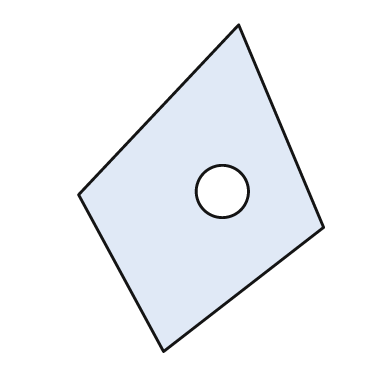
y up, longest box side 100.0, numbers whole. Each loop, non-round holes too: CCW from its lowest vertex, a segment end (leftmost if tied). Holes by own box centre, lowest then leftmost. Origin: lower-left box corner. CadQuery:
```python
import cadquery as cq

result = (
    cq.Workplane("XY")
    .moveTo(26.0, 0.0)
    .lineTo(75.0, 38.0)
    .lineTo(49.0, 100.0)
    .lineTo(0.0, 48.0)
    .close()
    .moveTo(44.0, 49.0)
    .circle(8.0)
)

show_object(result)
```